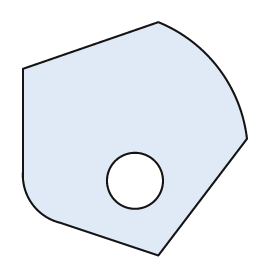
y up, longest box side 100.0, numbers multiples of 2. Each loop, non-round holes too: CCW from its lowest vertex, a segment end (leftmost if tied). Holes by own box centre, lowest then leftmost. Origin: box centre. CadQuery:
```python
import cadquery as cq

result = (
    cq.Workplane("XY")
    .moveTo(10.0, -50.0)
    .lineTo(48.0, 0.0)
    .threePointArc((36.0, 30.0), (10.0, 50.0))
    .lineTo(-48.0, 30.0)
    .lineTo(-48.0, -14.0)
    .threePointArc((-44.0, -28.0), (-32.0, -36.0))
    .close()
    .moveTo(0.0, -18.0)
    .circle(12.0)
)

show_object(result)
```